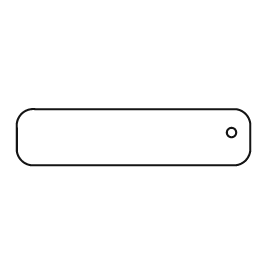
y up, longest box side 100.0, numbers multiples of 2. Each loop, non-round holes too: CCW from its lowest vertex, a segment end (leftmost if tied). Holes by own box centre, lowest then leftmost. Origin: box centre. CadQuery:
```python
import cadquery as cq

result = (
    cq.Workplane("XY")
    .moveTo(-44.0, -12.0)
    .lineTo(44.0, -12.0)
    .threePointArc((48.0, -10.0), (50.0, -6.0))
    .lineTo(50.0, 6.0)
    .threePointArc((48.0, 10.0), (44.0, 12.0))
    .lineTo(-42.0, 12.0)
    .threePointArc((-48.0, 10.0), (-50.0, 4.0))
    .lineTo(-50.0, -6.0)
    .threePointArc((-48.0, -10.0), (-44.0, -12.0))
    .close()
    .moveTo(42.0, 2.0)
    .circle(2.0)
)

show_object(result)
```